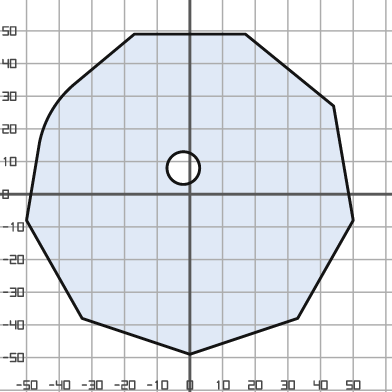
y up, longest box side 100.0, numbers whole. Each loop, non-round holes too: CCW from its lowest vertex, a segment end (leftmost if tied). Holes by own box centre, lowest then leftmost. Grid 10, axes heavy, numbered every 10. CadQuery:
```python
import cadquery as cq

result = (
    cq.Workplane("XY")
    .moveTo(0.0, -49.0)
    .lineTo(33.0, -38.0)
    .lineTo(50.0, -8.0)
    .lineTo(44.0, 27.0)
    .lineTo(17.0, 49.0)
    .lineTo(-17.0, 49.0)
    .lineTo(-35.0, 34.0)
    .threePointArc((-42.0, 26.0), (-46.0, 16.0))
    .lineTo(-50.0, -8.0)
    .lineTo(-33.0, -38.0)
    .close()
    .moveTo(-2.0, 8.0)
    .circle(5.0)
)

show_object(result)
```